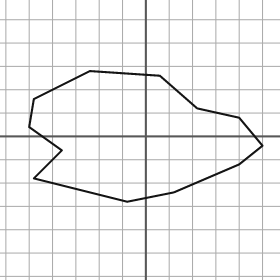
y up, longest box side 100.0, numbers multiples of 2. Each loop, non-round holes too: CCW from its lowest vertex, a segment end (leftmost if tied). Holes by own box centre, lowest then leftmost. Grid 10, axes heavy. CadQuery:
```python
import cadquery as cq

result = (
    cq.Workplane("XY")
    .moveTo(-8.0, -28.0)
    .lineTo(12.0, -24.0)
    .lineTo(40.0, -12.0)
    .lineTo(50.0, -4.0)
    .lineTo(40.0, 8.0)
    .lineTo(22.0, 12.0)
    .lineTo(6.0, 26.0)
    .lineTo(-24.0, 28.0)
    .lineTo(-48.0, 16.0)
    .lineTo(-50.0, 4.0)
    .lineTo(-36.0, -6.0)
    .lineTo(-48.0, -18.0)
    .close()
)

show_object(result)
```